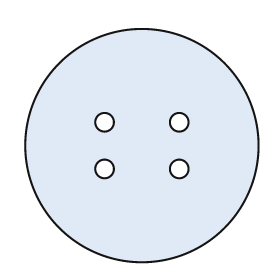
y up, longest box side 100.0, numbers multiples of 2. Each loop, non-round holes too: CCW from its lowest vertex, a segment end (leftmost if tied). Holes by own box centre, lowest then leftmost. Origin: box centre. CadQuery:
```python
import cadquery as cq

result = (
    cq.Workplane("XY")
    .moveTo(0.0, 0.0)
    .circle(50.0)
    .moveTo(-16.0, -10.0)
    .circle(4.0)
    .moveTo(16.0, -10.0)
    .circle(4.0)
    .moveTo(-16.0, 10.0)
    .circle(4.0)
    .moveTo(16.0, 10.0)
    .circle(4.0)
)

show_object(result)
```